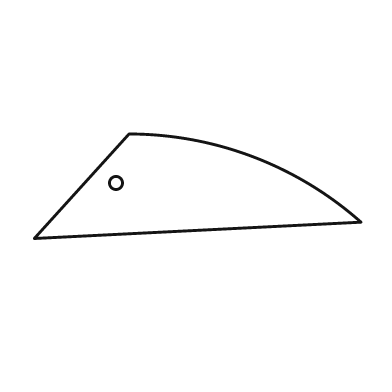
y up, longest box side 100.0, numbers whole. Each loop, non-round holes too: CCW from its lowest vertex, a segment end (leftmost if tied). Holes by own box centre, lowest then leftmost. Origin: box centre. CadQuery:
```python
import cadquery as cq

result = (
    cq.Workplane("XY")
    .moveTo(-50.0, -16.0)
    .lineTo(50.0, -11.0)
    .threePointArc((17.0, 9.0), (-21.0, 16.0))
    .close()
    .moveTo(-25.0, 1.0)
    .circle(2.0)
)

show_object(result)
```